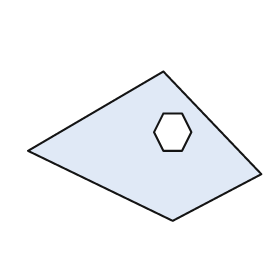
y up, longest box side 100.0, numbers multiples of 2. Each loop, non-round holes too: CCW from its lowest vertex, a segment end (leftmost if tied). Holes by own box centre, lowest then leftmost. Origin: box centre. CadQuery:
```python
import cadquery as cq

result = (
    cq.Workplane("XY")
    .moveTo(12.0, -32.0)
    .lineTo(50.0, -12.0)
    .lineTo(8.0, 32.0)
    .lineTo(-50.0, -2.0)
    .close()
    .moveTo(8.0, -2.0)
    .lineTo(16.0, -2.0)
    .lineTo(20.0, 6.0)
    .lineTo(16.0, 14.0)
    .lineTo(8.0, 14.0)
    .lineTo(4.0, 6.0)
    .close()
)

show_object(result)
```